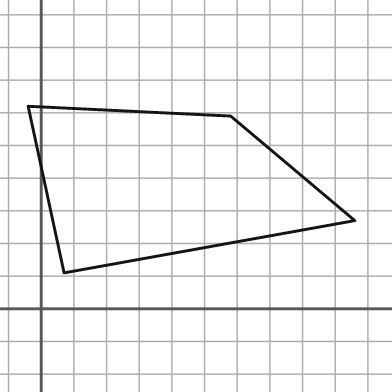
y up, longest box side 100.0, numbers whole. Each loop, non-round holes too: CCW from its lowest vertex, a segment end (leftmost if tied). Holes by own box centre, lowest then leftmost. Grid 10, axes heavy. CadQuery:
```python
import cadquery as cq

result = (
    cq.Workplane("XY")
    .moveTo(7.0, 11.0)
    .lineTo(96.0, 27.0)
    .lineTo(58.0, 59.0)
    .lineTo(-4.0, 62.0)
    .close()
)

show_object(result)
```